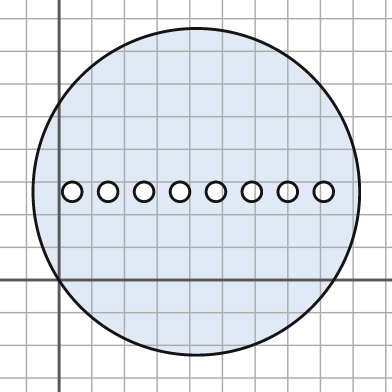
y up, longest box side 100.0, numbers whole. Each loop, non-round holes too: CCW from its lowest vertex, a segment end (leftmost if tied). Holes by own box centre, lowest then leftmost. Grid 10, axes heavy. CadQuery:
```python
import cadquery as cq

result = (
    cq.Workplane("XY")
    .moveTo(42.0, 27.0)
    .circle(50.0)
    .moveTo(4.0, 27.0)
    .circle(3.0)
    .moveTo(15.0, 27.0)
    .circle(3.0)
    .moveTo(26.0, 27.0)
    .circle(3.0)
    .moveTo(37.0, 27.0)
    .circle(3.0)
    .moveTo(48.0, 27.0)
    .circle(3.0)
    .moveTo(59.0, 27.0)
    .circle(3.0)
    .moveTo(70.0, 27.0)
    .circle(3.0)
    .moveTo(81.0, 27.0)
    .circle(3.0)
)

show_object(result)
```